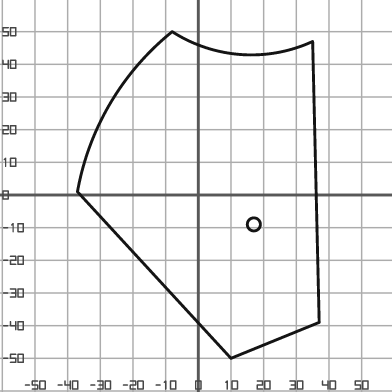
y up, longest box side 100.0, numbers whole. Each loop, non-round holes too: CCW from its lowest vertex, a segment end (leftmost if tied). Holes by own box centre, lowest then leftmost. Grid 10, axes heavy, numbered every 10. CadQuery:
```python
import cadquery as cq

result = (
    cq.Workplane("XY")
    .moveTo(10.0, -50.0)
    .lineTo(37.0, -39.0)
    .lineTo(35.0, 47.0)
    .threePointArc((13.0, 43.0), (-8.0, 50.0))
    .threePointArc((-27.0, 28.0), (-37.0, 1.0))
    .close()
    .moveTo(17.0, -9.0)
    .circle(2.0)
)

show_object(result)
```